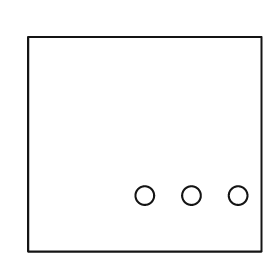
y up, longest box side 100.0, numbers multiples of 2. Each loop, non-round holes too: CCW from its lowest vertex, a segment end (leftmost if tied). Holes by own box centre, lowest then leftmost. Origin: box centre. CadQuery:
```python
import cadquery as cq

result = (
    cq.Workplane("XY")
    .moveTo(-50.0, -46.0)
    .lineTo(50.0, -46.0)
    .lineTo(50.0, 46.0)
    .lineTo(-50.0, 46.0)
    .close()
    .moveTo(0.0, -22.0)
    .circle(4.0)
    .moveTo(20.0, -22.0)
    .circle(4.0)
    .moveTo(40.0, -22.0)
    .circle(4.0)
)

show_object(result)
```